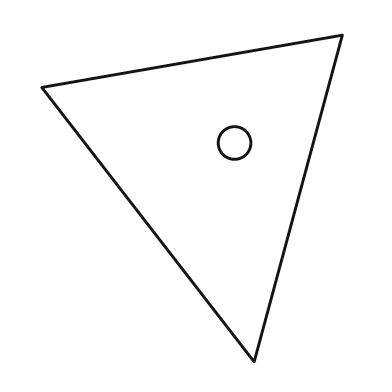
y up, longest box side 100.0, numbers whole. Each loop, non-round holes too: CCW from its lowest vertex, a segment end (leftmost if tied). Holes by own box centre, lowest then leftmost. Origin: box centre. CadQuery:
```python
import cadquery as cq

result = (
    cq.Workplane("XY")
    .moveTo(19.0, -50.0)
    .lineTo(46.0, 50.0)
    .lineTo(-46.0, 34.0)
    .close()
    .moveTo(13.0, 17.0)
    .circle(5.0)
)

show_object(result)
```